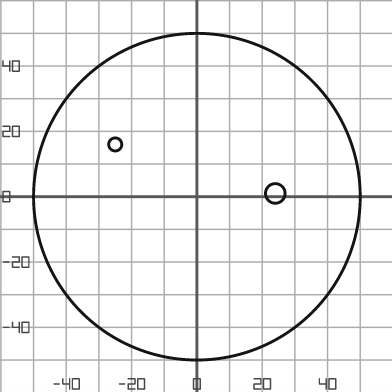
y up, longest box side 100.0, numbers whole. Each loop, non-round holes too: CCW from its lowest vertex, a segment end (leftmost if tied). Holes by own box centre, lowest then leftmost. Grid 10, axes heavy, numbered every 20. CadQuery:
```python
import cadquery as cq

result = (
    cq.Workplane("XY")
    .moveTo(0.0, 0.0)
    .circle(50.0)
    .moveTo(24.0, 1.0)
    .circle(3.0)
    .moveTo(-25.0, 16.0)
    .circle(2.0)
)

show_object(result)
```